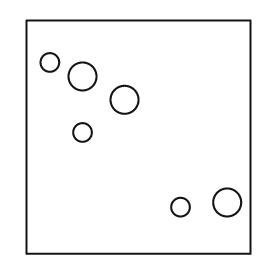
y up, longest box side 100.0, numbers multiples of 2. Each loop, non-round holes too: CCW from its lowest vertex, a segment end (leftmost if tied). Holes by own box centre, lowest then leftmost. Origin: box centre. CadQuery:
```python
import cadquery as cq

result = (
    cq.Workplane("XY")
    .moveTo(-48.0, -50.0)
    .lineTo(48.0, -50.0)
    .lineTo(48.0, 50.0)
    .lineTo(-48.0, 50.0)
    .close()
    .moveTo(18.0, -30.0)
    .circle(4.0)
    .moveTo(38.0, -28.0)
    .circle(6.0)
    .moveTo(-24.0, 2.0)
    .circle(4.0)
    .moveTo(-6.0, 16.0)
    .circle(6.0)
    .moveTo(-24.0, 26.0)
    .circle(6.0)
    .moveTo(-38.0, 32.0)
    .circle(4.0)
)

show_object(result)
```